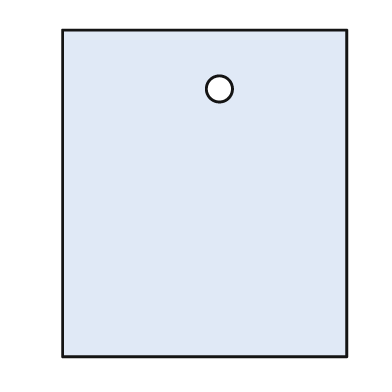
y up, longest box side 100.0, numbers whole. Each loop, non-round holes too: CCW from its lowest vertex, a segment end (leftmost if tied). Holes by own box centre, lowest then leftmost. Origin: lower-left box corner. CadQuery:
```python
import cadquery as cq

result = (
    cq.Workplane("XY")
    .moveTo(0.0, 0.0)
    .lineTo(87.0, 0.0)
    .lineTo(87.0, 100.0)
    .lineTo(0.0, 100.0)
    .close()
    .moveTo(48.0, 82.0)
    .circle(4.0)
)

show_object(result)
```